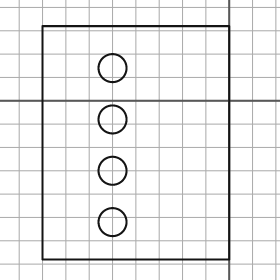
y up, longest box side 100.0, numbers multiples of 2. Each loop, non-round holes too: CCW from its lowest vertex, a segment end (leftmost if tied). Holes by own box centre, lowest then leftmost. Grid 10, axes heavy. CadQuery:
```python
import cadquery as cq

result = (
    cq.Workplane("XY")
    .moveTo(-80.0, -68.0)
    .lineTo(0.0, -68.0)
    .lineTo(0.0, 32.0)
    .lineTo(-80.0, 32.0)
    .close()
    .moveTo(-50.0, -52.0)
    .circle(6.0)
    .moveTo(-50.0, -30.0)
    .circle(6.0)
    .moveTo(-50.0, -8.0)
    .circle(6.0)
    .moveTo(-50.0, 14.0)
    .circle(6.0)
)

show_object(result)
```